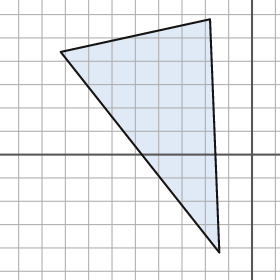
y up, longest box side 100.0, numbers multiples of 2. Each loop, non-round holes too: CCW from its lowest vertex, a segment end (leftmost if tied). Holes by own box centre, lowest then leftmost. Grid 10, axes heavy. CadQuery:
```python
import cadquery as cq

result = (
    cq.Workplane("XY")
    .moveTo(-14.0, -42.0)
    .lineTo(-18.0, 58.0)
    .lineTo(-82.0, 44.0)
    .close()
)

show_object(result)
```